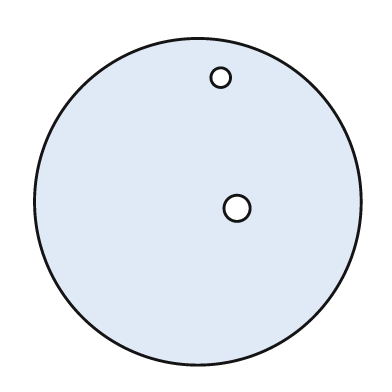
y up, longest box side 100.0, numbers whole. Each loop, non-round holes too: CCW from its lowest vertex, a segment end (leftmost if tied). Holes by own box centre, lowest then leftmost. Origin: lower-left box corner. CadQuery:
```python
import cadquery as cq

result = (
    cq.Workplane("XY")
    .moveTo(50.0, 50.0)
    .circle(50.0)
    .moveTo(62.0, 48.0)
    .circle(4.0)
    .moveTo(57.0, 88.0)
    .circle(3.0)
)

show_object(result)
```